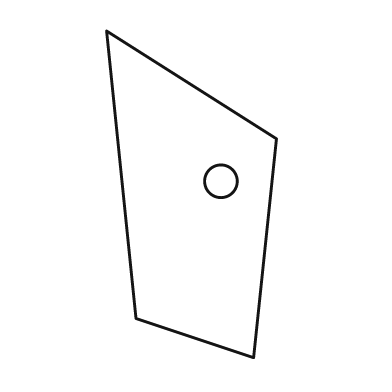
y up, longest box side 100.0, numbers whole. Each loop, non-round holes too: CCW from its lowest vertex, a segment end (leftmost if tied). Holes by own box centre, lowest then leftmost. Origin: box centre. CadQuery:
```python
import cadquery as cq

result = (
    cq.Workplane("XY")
    .moveTo(19.0, -50.0)
    .lineTo(26.0, 17.0)
    .lineTo(-26.0, 50.0)
    .lineTo(-17.0, -38.0)
    .close()
    .moveTo(9.0, 4.0)
    .circle(5.0)
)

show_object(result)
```